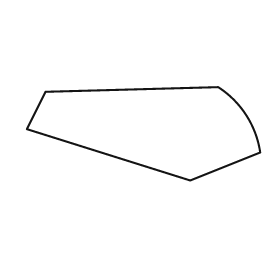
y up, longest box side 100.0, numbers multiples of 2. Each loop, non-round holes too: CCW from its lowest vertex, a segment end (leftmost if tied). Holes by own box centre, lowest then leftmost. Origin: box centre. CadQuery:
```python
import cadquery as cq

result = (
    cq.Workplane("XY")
    .moveTo(20.0, -20.0)
    .lineTo(50.0, -8.0)
    .threePointArc((44.0, 8.0), (32.0, 20.0))
    .lineTo(-42.0, 18.0)
    .lineTo(-50.0, 2.0)
    .close()
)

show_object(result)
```